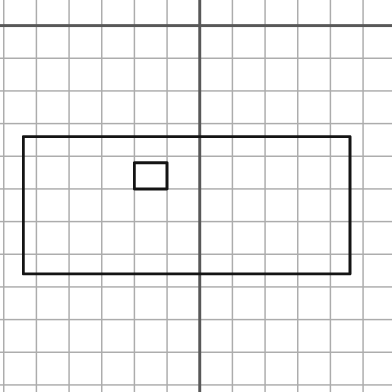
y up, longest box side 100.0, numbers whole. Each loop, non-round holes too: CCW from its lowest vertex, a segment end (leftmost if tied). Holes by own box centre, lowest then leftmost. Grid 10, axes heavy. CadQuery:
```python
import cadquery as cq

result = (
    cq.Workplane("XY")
    .moveTo(-54.0, -76.0)
    .lineTo(46.0, -76.0)
    .lineTo(46.0, -34.0)
    .lineTo(-54.0, -34.0)
    .close()
    .moveTo(-20.0, -50.0)
    .lineTo(-10.0, -50.0)
    .lineTo(-10.0, -42.0)
    .lineTo(-20.0, -42.0)
    .close()
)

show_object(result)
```